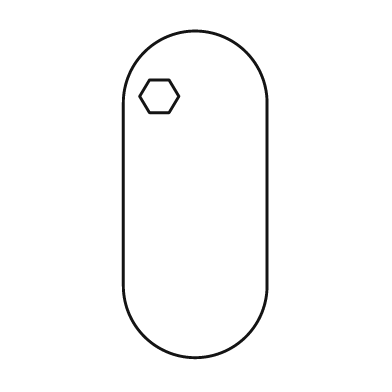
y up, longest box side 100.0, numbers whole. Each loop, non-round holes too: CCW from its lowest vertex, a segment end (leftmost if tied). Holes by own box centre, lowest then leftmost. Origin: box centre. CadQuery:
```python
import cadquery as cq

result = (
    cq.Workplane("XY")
    .moveTo(-22.0, -28.0)
    .threePointArc((0.0, -50.0), (22.0, -28.0))
    .lineTo(22.0, 28.0)
    .threePointArc((0.0, 50.0), (-22.0, 28.0))
    .close()
    .moveTo(-14.0, 25.0)
    .lineTo(-8.0, 25.0)
    .lineTo(-5.0, 30.0)
    .lineTo(-8.0, 35.0)
    .lineTo(-14.0, 35.0)
    .lineTo(-17.0, 30.0)
    .close()
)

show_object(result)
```